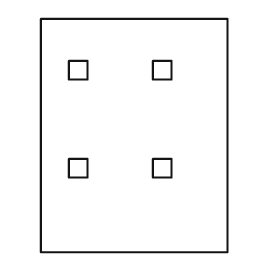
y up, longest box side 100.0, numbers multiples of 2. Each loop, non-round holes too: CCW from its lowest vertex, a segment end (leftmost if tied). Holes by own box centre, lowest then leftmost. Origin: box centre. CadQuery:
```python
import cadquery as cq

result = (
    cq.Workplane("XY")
    .moveTo(-40.0, -50.0)
    .lineTo(40.0, -50.0)
    .lineTo(40.0, 50.0)
    .lineTo(-40.0, 50.0)
    .close()
    .moveTo(-28.0, -18.0)
    .lineTo(-20.0, -18.0)
    .lineTo(-20.0, -10.0)
    .lineTo(-28.0, -10.0)
    .close()
    .moveTo(8.0, -18.0)
    .lineTo(16.0, -18.0)
    .lineTo(16.0, -10.0)
    .lineTo(8.0, -10.0)
    .close()
    .moveTo(-28.0, 24.0)
    .lineTo(-20.0, 24.0)
    .lineTo(-20.0, 32.0)
    .lineTo(-28.0, 32.0)
    .close()
    .moveTo(8.0, 24.0)
    .lineTo(16.0, 24.0)
    .lineTo(16.0, 32.0)
    .lineTo(8.0, 32.0)
    .close()
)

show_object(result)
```